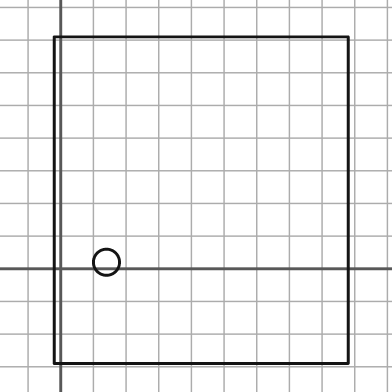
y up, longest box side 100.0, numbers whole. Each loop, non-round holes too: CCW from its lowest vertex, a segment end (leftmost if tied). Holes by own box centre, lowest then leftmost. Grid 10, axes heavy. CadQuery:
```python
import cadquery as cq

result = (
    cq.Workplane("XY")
    .moveTo(-2.0, -29.0)
    .lineTo(88.0, -29.0)
    .lineTo(88.0, 71.0)
    .lineTo(-2.0, 71.0)
    .close()
    .moveTo(14.0, 2.0)
    .circle(4.0)
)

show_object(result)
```